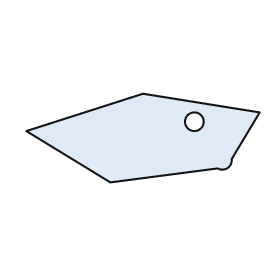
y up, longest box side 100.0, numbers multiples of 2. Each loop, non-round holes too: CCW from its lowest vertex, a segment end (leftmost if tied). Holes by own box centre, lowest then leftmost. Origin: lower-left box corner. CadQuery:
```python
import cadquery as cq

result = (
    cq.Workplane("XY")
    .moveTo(36.0, 0.0)
    .lineTo(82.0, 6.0)
    .threePointArc((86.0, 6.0), (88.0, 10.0))
    .lineTo(100.0, 30.0)
    .lineTo(50.0, 38.0)
    .lineTo(0.0, 22.0)
    .close()
    .moveTo(72.0, 26.0)
    .circle(4.0)
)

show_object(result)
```